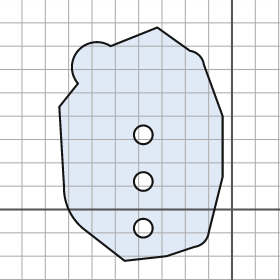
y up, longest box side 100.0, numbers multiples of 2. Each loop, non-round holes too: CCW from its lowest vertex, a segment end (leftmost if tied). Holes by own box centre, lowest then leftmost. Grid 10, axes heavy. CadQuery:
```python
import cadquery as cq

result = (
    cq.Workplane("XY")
    .moveTo(-46.0, -22.0)
    .lineTo(-28.0, -20.0)
    .lineTo(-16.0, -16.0)
    .threePointArc((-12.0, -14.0), (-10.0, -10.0))
    .lineTo(-4.0, 14.0)
    .lineTo(-4.0, 40.0)
    .lineTo(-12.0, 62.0)
    .threePointArc((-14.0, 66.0), (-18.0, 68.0))
    .lineTo(-32.0, 78.0)
    .lineTo(-52.0, 70.0)
    .threePointArc((-66.0, 68.0), (-66.0, 54.0))
    .lineTo(-74.0, 44.0)
    .lineTo(-72.0, 10.0)
    .threePointArc((-70.0, 0.0), (-64.0, -8.0))
    .close()
    .moveTo(-38.0, -8.0)
    .circle(4.0)
    .moveTo(-38.0, 12.0)
    .circle(4.0)
    .moveTo(-38.0, 32.0)
    .circle(4.0)
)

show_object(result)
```